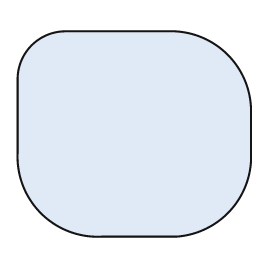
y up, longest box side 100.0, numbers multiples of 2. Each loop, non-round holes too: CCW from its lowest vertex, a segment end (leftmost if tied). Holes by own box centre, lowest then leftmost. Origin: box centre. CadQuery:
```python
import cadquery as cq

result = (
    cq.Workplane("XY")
    .moveTo(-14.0, -44.0)
    .lineTo(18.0, -44.0)
    .threePointArc((40.0, -34.0), (50.0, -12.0))
    .lineTo(50.0, 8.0)
    .threePointArc((40.0, 34.0), (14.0, 44.0))
    .lineTo(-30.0, 44.0)
    .threePointArc((-44.0, 38.0), (-50.0, 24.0))
    .lineTo(-50.0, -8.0)
    .threePointArc((-40.0, -34.0), (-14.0, -44.0))
    .close()
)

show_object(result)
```